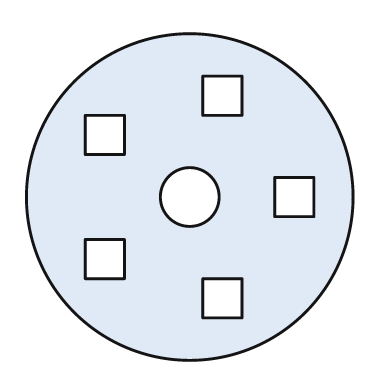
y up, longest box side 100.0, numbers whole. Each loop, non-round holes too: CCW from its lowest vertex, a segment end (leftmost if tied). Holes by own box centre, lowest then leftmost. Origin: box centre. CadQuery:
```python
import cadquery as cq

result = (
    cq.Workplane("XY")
    .moveTo(0.0, 0.0)
    .circle(50.0)
    .moveTo(4.0, -37.0)
    .lineTo(16.0, -37.0)
    .lineTo(16.0, -25.0)
    .lineTo(4.0, -25.0)
    .close()
    .moveTo(-32.0, -25.0)
    .lineTo(-20.0, -25.0)
    .lineTo(-20.0, -13.0)
    .lineTo(-32.0, -13.0)
    .close()
    .moveTo(0.0, 0.0)
    .circle(9.0)
    .moveTo(26.0, -6.0)
    .lineTo(38.0, -6.0)
    .lineTo(38.0, 6.0)
    .lineTo(26.0, 6.0)
    .close()
    .moveTo(-32.0, 13.0)
    .lineTo(-20.0, 13.0)
    .lineTo(-20.0, 25.0)
    .lineTo(-32.0, 25.0)
    .close()
    .moveTo(4.0, 25.0)
    .lineTo(16.0, 25.0)
    .lineTo(16.0, 37.0)
    .lineTo(4.0, 37.0)
    .close()
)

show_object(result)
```